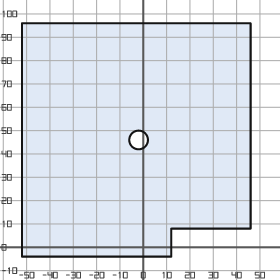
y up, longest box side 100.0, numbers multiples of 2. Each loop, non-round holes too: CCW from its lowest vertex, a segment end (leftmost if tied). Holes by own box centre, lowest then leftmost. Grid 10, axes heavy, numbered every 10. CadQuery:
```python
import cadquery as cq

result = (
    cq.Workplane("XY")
    .moveTo(-52.0, -4.0)
    .lineTo(12.0, -4.0)
    .lineTo(12.0, 8.0)
    .lineTo(46.0, 8.0)
    .lineTo(46.0, 96.0)
    .lineTo(-52.0, 96.0)
    .close()
    .moveTo(-2.0, 46.0)
    .circle(4.0)
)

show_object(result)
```